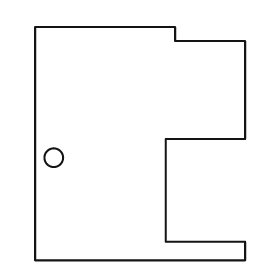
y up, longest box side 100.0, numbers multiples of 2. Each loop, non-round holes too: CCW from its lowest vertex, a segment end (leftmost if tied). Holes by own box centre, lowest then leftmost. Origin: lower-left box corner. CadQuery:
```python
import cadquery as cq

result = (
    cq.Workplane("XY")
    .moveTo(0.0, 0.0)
    .lineTo(90.0, 0.0)
    .lineTo(90.0, 8.0)
    .lineTo(56.0, 8.0)
    .lineTo(56.0, 52.0)
    .lineTo(90.0, 52.0)
    .lineTo(90.0, 94.0)
    .lineTo(60.0, 94.0)
    .lineTo(60.0, 100.0)
    .lineTo(0.0, 100.0)
    .close()
    .moveTo(8.0, 44.0)
    .circle(4.0)
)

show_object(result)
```